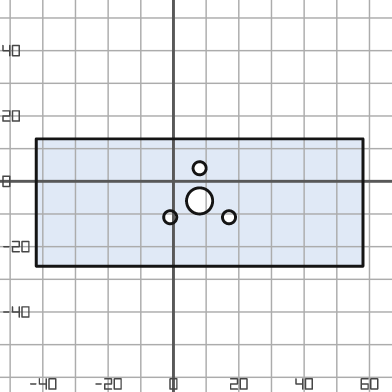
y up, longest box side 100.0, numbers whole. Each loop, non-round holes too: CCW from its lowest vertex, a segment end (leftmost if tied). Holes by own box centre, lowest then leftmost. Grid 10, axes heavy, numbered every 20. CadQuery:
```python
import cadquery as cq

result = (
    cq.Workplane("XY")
    .moveTo(-42.0, -26.0)
    .lineTo(58.0, -26.0)
    .lineTo(58.0, 13.0)
    .lineTo(-42.0, 13.0)
    .close()
    .moveTo(-1.0, -11.0)
    .circle(2.0)
    .moveTo(17.0, -11.0)
    .circle(2.0)
    .moveTo(8.0, -6.0)
    .circle(4.0)
    .moveTo(8.0, 4.0)
    .circle(2.0)
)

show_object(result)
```